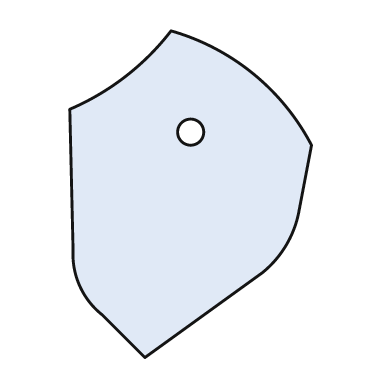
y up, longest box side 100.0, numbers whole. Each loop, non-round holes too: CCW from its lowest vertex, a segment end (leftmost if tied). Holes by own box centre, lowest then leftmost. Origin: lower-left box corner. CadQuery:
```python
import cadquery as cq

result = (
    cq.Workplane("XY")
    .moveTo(23.0, 0.0)
    .lineTo(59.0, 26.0)
    .threePointArc((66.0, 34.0), (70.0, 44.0))
    .lineTo(74.0, 65.0)
    .threePointArc((56.0, 87.0), (31.0, 100.0))
    .threePointArc((17.0, 86.0), (0.0, 76.0))
    .lineTo(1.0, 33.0)
    .threePointArc((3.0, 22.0), (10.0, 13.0))
    .close()
    .moveTo(37.0, 69.0)
    .circle(4.0)
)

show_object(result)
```